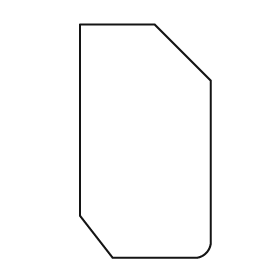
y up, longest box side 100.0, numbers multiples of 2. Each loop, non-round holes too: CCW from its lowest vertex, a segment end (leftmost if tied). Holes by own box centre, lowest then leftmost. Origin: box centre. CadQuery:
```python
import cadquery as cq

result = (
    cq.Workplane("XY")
    .moveTo(-14.0, -50.0)
    .lineTo(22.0, -50.0)
    .threePointArc((26.0, -48.0), (28.0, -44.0))
    .lineTo(28.0, 26.0)
    .lineTo(4.0, 50.0)
    .lineTo(-28.0, 50.0)
    .lineTo(-28.0, -32.0)
    .close()
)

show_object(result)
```